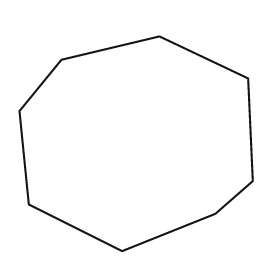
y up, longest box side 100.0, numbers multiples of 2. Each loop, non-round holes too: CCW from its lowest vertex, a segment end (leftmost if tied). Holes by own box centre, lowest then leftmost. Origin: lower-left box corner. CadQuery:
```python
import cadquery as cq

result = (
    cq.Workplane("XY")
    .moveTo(44.0, 0.0)
    .lineTo(84.0, 16.0)
    .lineTo(100.0, 30.0)
    .lineTo(98.0, 74.0)
    .lineTo(60.0, 92.0)
    .lineTo(18.0, 82.0)
    .lineTo(0.0, 60.0)
    .lineTo(4.0, 20.0)
    .close()
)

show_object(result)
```